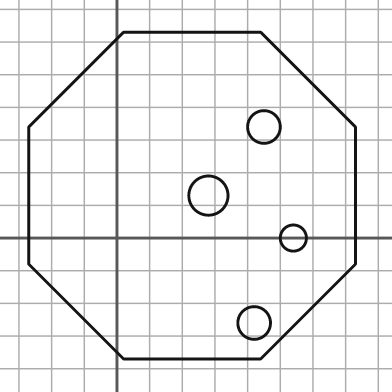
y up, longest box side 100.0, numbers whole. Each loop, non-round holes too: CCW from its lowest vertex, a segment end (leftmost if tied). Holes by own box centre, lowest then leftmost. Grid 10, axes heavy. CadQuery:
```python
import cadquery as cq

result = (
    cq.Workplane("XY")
    .moveTo(2.0, -37.0)
    .lineTo(44.0, -37.0)
    .lineTo(73.0, -8.0)
    .lineTo(73.0, 34.0)
    .lineTo(44.0, 63.0)
    .lineTo(2.0, 63.0)
    .lineTo(-27.0, 34.0)
    .lineTo(-27.0, -8.0)
    .close()
    .moveTo(42.0, -26.0)
    .circle(5.0)
    .moveTo(54.0, 0.0)
    .circle(4.0)
    .moveTo(28.0, 13.0)
    .circle(6.0)
    .moveTo(45.0, 34.0)
    .circle(5.0)
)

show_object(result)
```